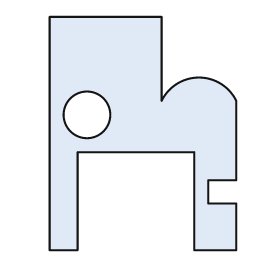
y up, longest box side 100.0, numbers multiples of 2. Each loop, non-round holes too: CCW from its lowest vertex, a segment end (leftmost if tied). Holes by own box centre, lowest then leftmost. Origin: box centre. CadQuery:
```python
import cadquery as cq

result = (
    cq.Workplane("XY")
    .moveTo(-40.0, -50.0)
    .lineTo(-28.0, -50.0)
    .lineTo(-28.0, -8.0)
    .lineTo(22.0, -8.0)
    .lineTo(22.0, -50.0)
    .lineTo(40.0, -50.0)
    .lineTo(40.0, -30.0)
    .lineTo(28.0, -30.0)
    .lineTo(28.0, -20.0)
    .lineTo(40.0, -20.0)
    .lineTo(40.0, 14.0)
    .threePointArc((24.0, 24.0), (8.0, 14.0))
    .lineTo(8.0, 50.0)
    .lineTo(-40.0, 50.0)
    .close()
    .moveTo(-24.0, 8.0)
    .circle(10.0)
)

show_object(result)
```